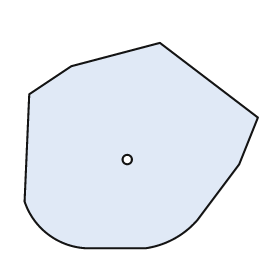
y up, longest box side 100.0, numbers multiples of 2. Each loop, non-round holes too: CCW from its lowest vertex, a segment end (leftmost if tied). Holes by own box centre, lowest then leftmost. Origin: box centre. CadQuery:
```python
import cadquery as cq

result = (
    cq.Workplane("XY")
    .moveTo(-24.0, -44.0)
    .lineTo(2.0, -44.0)
    .threePointArc((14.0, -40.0), (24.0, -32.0))
    .lineTo(42.0, -8.0)
    .lineTo(50.0, 12.0)
    .lineTo(8.0, 44.0)
    .lineTo(-30.0, 34.0)
    .lineTo(-48.0, 22.0)
    .lineTo(-50.0, -24.0)
    .threePointArc((-40.0, -38.0), (-24.0, -44.0))
    .close()
    .moveTo(-6.0, -6.0)
    .circle(2.0)
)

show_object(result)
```